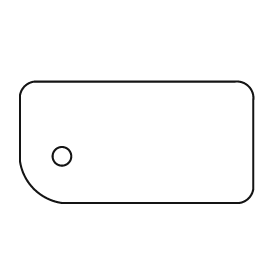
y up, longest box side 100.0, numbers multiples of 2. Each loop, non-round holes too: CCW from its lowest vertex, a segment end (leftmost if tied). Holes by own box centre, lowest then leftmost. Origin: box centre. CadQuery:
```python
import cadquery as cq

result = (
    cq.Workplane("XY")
    .moveTo(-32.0, -26.0)
    .lineTo(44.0, -26.0)
    .threePointArc((48.0, -24.0), (50.0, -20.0))
    .lineTo(50.0, 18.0)
    .threePointArc((48.0, 24.0), (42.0, 26.0))
    .lineTo(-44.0, 26.0)
    .threePointArc((-48.0, 24.0), (-50.0, 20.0))
    .lineTo(-50.0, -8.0)
    .threePointArc((-44.0, -20.0), (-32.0, -26.0))
    .close()
    .moveTo(-32.0, -6.0)
    .circle(4.0)
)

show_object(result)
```